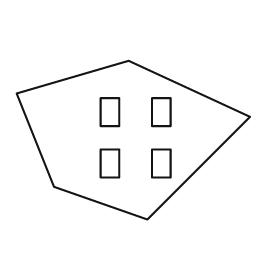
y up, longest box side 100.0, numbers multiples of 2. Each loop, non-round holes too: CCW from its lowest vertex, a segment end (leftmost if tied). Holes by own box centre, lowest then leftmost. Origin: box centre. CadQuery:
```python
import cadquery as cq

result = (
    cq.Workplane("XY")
    .moveTo(6.0, -34.0)
    .lineTo(50.0, 10.0)
    .lineTo(-2.0, 34.0)
    .lineTo(-50.0, 20.0)
    .lineTo(-34.0, -20.0)
    .close()
    .moveTo(-14.0, -16.0)
    .lineTo(-6.0, -16.0)
    .lineTo(-6.0, -4.0)
    .lineTo(-14.0, -4.0)
    .close()
    .moveTo(8.0, -16.0)
    .lineTo(16.0, -16.0)
    .lineTo(16.0, -4.0)
    .lineTo(8.0, -4.0)
    .close()
    .moveTo(-14.0, 6.0)
    .lineTo(-6.0, 6.0)
    .lineTo(-6.0, 18.0)
    .lineTo(-14.0, 18.0)
    .close()
    .moveTo(8.0, 6.0)
    .lineTo(16.0, 6.0)
    .lineTo(16.0, 18.0)
    .lineTo(8.0, 18.0)
    .close()
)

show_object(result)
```